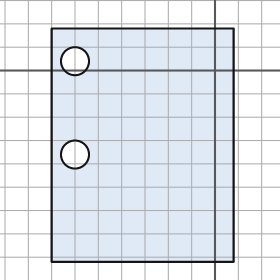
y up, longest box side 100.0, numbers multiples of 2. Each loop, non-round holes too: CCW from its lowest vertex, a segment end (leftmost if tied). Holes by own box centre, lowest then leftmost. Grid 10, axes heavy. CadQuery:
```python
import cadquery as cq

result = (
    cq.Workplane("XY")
    .moveTo(-70.0, -82.0)
    .lineTo(8.0, -82.0)
    .lineTo(8.0, 18.0)
    .lineTo(-70.0, 18.0)
    .close()
    .moveTo(-60.0, -36.0)
    .circle(6.0)
    .moveTo(-60.0, 4.0)
    .circle(6.0)
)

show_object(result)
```